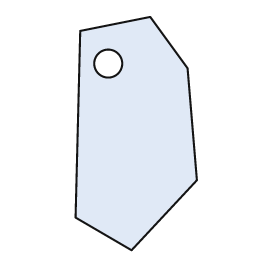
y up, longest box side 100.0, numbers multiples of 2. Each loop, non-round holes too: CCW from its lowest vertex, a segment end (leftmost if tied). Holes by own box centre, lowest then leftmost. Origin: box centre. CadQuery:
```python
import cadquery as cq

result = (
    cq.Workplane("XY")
    .moveTo(-2.0, -50.0)
    .lineTo(26.0, -20.0)
    .lineTo(22.0, 28.0)
    .lineTo(6.0, 50.0)
    .lineTo(-24.0, 44.0)
    .lineTo(-26.0, -36.0)
    .close()
    .moveTo(-12.0, 30.0)
    .circle(6.0)
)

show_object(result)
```